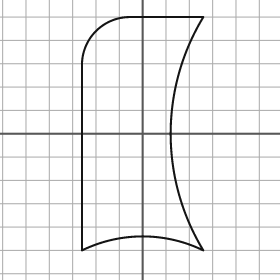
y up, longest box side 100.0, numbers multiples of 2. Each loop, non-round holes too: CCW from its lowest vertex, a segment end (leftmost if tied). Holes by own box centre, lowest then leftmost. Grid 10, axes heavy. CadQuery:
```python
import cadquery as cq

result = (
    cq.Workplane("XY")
    .moveTo(-26.0, -50.0)
    .threePointArc((0.0, -44.0), (26.0, -50.0))
    .threePointArc((12.0, 0.0), (26.0, 50.0))
    .lineTo(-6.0, 50.0)
    .threePointArc((-20.0, 44.0), (-26.0, 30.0))
    .close()
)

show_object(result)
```